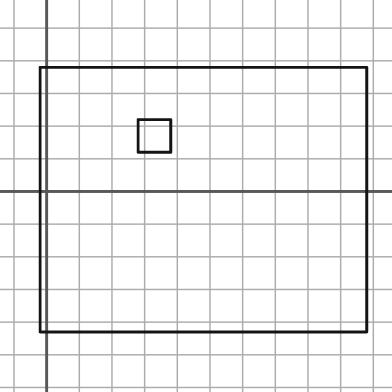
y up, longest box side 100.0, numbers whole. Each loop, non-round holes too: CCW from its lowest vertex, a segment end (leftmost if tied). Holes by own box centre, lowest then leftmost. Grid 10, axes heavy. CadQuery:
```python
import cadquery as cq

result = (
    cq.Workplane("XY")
    .moveTo(-2.0, -43.0)
    .lineTo(98.0, -43.0)
    .lineTo(98.0, 38.0)
    .lineTo(-2.0, 38.0)
    .close()
    .moveTo(28.0, 12.0)
    .lineTo(38.0, 12.0)
    .lineTo(38.0, 22.0)
    .lineTo(28.0, 22.0)
    .close()
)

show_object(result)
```